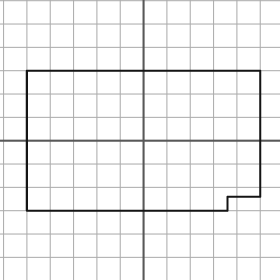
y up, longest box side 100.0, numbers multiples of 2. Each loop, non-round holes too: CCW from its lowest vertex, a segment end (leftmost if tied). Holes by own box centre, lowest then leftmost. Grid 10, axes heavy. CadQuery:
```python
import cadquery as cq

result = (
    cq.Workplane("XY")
    .moveTo(-50.0, -30.0)
    .lineTo(36.0, -30.0)
    .lineTo(36.0, -24.0)
    .lineTo(50.0, -24.0)
    .lineTo(50.0, 30.0)
    .lineTo(-50.0, 30.0)
    .close()
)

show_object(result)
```